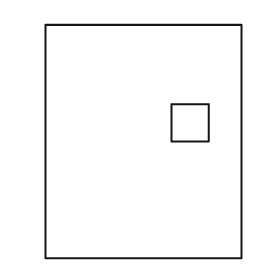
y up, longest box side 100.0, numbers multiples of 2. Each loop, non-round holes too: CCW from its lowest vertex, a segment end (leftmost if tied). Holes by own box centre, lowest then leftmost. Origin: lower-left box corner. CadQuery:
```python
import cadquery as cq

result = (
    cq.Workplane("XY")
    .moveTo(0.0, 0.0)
    .lineTo(84.0, 0.0)
    .lineTo(84.0, 100.0)
    .lineTo(0.0, 100.0)
    .close()
    .moveTo(54.0, 50.0)
    .lineTo(70.0, 50.0)
    .lineTo(70.0, 66.0)
    .lineTo(54.0, 66.0)
    .close()
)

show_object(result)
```